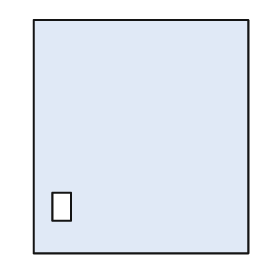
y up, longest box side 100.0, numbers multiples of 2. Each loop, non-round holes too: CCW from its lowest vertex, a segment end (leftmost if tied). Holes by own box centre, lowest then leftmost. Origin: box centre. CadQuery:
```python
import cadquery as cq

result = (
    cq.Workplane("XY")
    .moveTo(-46.0, -50.0)
    .lineTo(46.0, -50.0)
    .lineTo(46.0, 50.0)
    .lineTo(-46.0, 50.0)
    .close()
    .moveTo(-38.0, -36.0)
    .lineTo(-30.0, -36.0)
    .lineTo(-30.0, -24.0)
    .lineTo(-38.0, -24.0)
    .close()
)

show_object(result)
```